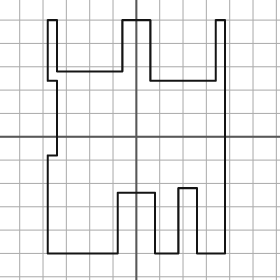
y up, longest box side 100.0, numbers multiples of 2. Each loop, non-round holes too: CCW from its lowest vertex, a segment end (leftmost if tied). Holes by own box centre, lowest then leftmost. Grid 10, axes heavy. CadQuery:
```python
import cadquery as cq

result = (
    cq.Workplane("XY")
    .moveTo(-38.0, -50.0)
    .lineTo(-8.0, -50.0)
    .lineTo(-8.0, -24.0)
    .lineTo(8.0, -24.0)
    .lineTo(8.0, -50.0)
    .lineTo(18.0, -50.0)
    .lineTo(18.0, -22.0)
    .lineTo(26.0, -22.0)
    .lineTo(26.0, -50.0)
    .lineTo(38.0, -50.0)
    .lineTo(38.0, 50.0)
    .lineTo(34.0, 50.0)
    .lineTo(34.0, 24.0)
    .lineTo(6.0, 24.0)
    .lineTo(6.0, 50.0)
    .lineTo(-6.0, 50.0)
    .lineTo(-6.0, 28.0)
    .lineTo(-34.0, 28.0)
    .lineTo(-34.0, 50.0)
    .lineTo(-38.0, 50.0)
    .lineTo(-38.0, 24.0)
    .lineTo(-34.0, 24.0)
    .lineTo(-34.0, -8.0)
    .lineTo(-38.0, -8.0)
    .close()
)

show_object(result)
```